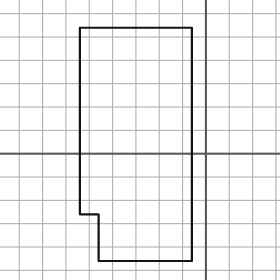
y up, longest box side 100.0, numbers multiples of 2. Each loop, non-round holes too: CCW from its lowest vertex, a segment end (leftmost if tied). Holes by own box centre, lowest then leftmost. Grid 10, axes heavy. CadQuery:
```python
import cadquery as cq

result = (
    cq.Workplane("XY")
    .moveTo(-46.0, -46.0)
    .lineTo(-6.0, -46.0)
    .lineTo(-6.0, 54.0)
    .lineTo(-54.0, 54.0)
    .lineTo(-54.0, -26.0)
    .lineTo(-46.0, -26.0)
    .close()
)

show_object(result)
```